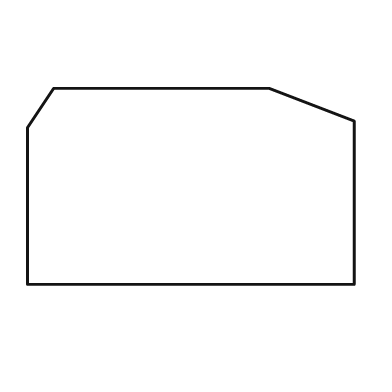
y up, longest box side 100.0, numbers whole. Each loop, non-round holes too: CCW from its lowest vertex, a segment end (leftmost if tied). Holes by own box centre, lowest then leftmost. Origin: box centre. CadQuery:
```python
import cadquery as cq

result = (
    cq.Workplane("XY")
    .moveTo(-50.0, -30.0)
    .lineTo(50.0, -30.0)
    .lineTo(50.0, 20.0)
    .lineTo(24.0, 30.0)
    .lineTo(-42.0, 30.0)
    .lineTo(-50.0, 18.0)
    .close()
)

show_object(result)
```